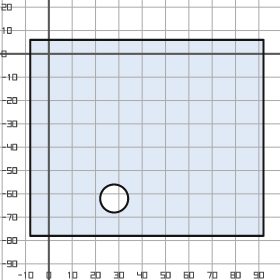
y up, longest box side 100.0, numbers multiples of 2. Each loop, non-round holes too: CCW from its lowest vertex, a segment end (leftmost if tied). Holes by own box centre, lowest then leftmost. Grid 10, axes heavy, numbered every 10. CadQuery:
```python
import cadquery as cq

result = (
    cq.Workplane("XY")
    .moveTo(-8.0, -78.0)
    .lineTo(92.0, -78.0)
    .lineTo(92.0, 6.0)
    .lineTo(-8.0, 6.0)
    .close()
    .moveTo(28.0, -62.0)
    .circle(6.0)
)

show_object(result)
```